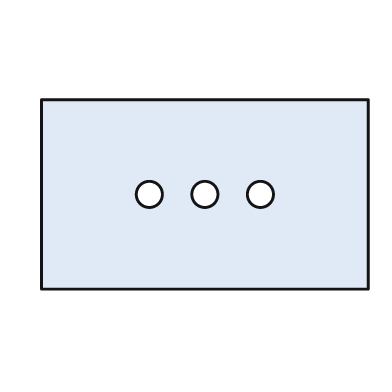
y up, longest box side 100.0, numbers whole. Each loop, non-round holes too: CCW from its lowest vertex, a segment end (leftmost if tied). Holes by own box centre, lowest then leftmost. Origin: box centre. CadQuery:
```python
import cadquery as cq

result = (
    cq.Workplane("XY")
    .moveTo(-50.0, -29.0)
    .lineTo(50.0, -29.0)
    .lineTo(50.0, 29.0)
    .lineTo(-50.0, 29.0)
    .close()
    .moveTo(-17.0, 0.0)
    .circle(4.0)
    .moveTo(0.0, 0.0)
    .circle(4.0)
    .moveTo(17.0, 0.0)
    .circle(4.0)
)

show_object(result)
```